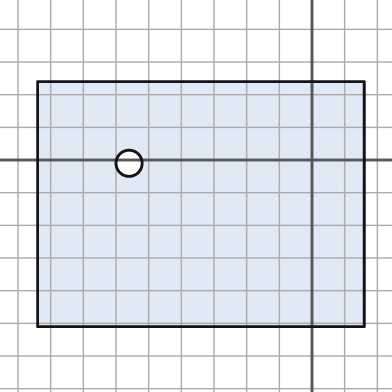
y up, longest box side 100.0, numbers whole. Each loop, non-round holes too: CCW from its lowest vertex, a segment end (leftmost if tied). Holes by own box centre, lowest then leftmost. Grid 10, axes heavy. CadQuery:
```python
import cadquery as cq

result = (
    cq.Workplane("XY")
    .moveTo(-84.0, -51.0)
    .lineTo(16.0, -51.0)
    .lineTo(16.0, 24.0)
    .lineTo(-84.0, 24.0)
    .close()
    .moveTo(-56.0, -1.0)
    .circle(4.0)
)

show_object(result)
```